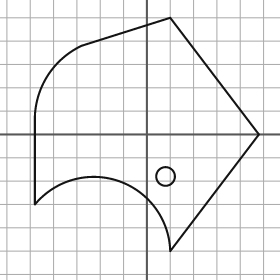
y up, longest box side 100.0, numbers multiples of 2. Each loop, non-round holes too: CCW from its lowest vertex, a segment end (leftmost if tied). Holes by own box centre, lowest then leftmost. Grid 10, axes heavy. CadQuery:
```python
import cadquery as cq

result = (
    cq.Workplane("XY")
    .moveTo(10.0, -50.0)
    .lineTo(48.0, 0.0)
    .lineTo(10.0, 50.0)
    .lineTo(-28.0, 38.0)
    .threePointArc((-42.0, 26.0), (-48.0, 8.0))
    .lineTo(-48.0, -30.0)
    .threePointArc((-12.0, -20.0), (10.0, -50.0))
    .close()
    .moveTo(8.0, -18.0)
    .circle(4.0)
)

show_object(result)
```